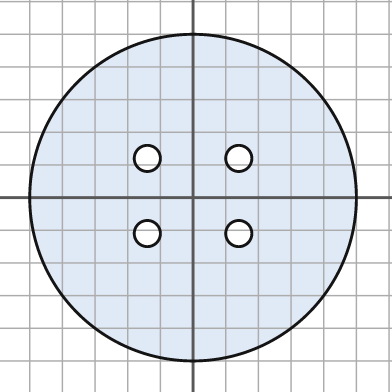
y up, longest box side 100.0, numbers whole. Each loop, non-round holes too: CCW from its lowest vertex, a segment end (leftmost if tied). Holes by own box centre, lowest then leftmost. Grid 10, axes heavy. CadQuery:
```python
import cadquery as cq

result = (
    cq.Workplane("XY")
    .moveTo(0.0, 0.0)
    .circle(50.0)
    .moveTo(-14.0, -11.0)
    .circle(4.0)
    .moveTo(14.0, -11.0)
    .circle(4.0)
    .moveTo(-14.0, 12.0)
    .circle(4.0)
    .moveTo(14.0, 12.0)
    .circle(4.0)
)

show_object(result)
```